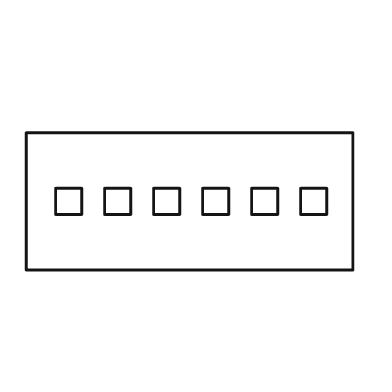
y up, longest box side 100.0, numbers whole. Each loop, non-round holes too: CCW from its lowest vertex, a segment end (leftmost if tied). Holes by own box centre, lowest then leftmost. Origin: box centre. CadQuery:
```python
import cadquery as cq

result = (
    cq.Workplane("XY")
    .moveTo(-50.0, -21.0)
    .lineTo(50.0, -21.0)
    .lineTo(50.0, 21.0)
    .lineTo(-50.0, 21.0)
    .close()
    .moveTo(-41.0, -4.0)
    .lineTo(-33.0, -4.0)
    .lineTo(-33.0, 4.0)
    .lineTo(-41.0, 4.0)
    .close()
    .moveTo(-26.0, -4.0)
    .lineTo(-18.0, -4.0)
    .lineTo(-18.0, 4.0)
    .lineTo(-26.0, 4.0)
    .close()
    .moveTo(-11.0, -4.0)
    .lineTo(-3.0, -4.0)
    .lineTo(-3.0, 4.0)
    .lineTo(-11.0, 4.0)
    .close()
    .moveTo(4.0, -4.0)
    .lineTo(12.0, -4.0)
    .lineTo(12.0, 4.0)
    .lineTo(4.0, 4.0)
    .close()
    .moveTo(19.0, -4.0)
    .lineTo(27.0, -4.0)
    .lineTo(27.0, 4.0)
    .lineTo(19.0, 4.0)
    .close()
    .moveTo(34.0, -4.0)
    .lineTo(42.0, -4.0)
    .lineTo(42.0, 4.0)
    .lineTo(34.0, 4.0)
    .close()
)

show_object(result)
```